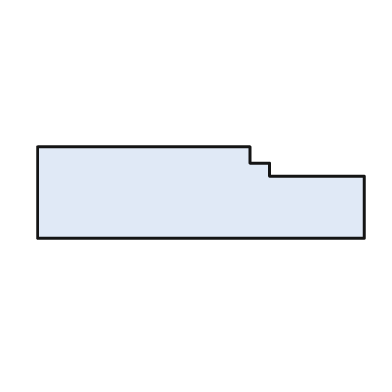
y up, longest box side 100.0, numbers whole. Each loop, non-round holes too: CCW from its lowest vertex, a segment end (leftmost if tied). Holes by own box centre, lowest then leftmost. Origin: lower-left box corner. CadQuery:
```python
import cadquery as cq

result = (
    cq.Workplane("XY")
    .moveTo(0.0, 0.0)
    .lineTo(100.0, 0.0)
    .lineTo(100.0, 19.0)
    .lineTo(71.0, 19.0)
    .lineTo(71.0, 23.0)
    .lineTo(65.0, 23.0)
    .lineTo(65.0, 28.0)
    .lineTo(0.0, 28.0)
    .close()
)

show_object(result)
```